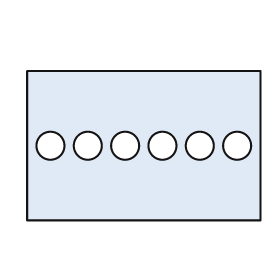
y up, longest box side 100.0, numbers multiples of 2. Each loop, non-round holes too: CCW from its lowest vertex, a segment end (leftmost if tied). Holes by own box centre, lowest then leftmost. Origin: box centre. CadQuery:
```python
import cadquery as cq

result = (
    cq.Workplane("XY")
    .moveTo(-50.0, -32.0)
    .lineTo(50.0, -32.0)
    .lineTo(50.0, 32.0)
    .lineTo(-50.0, 32.0)
    .close()
    .moveTo(-40.0, 0.0)
    .circle(6.0)
    .moveTo(-24.0, 0.0)
    .circle(6.0)
    .moveTo(-8.0, 0.0)
    .circle(6.0)
    .moveTo(8.0, 0.0)
    .circle(6.0)
    .moveTo(24.0, 0.0)
    .circle(6.0)
    .moveTo(40.0, 0.0)
    .circle(6.0)
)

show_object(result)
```